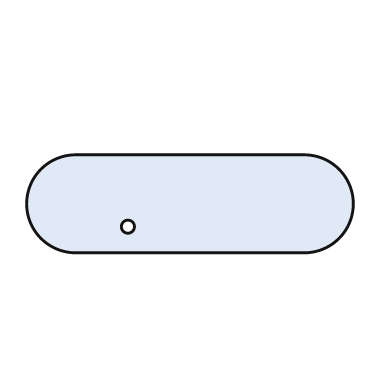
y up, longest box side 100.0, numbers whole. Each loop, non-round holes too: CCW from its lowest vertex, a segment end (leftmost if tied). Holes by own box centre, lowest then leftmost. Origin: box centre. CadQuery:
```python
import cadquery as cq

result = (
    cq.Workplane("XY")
    .moveTo(-35.0, -15.0)
    .lineTo(35.0, -15.0)
    .threePointArc((50.0, 0.0), (35.0, 15.0))
    .lineTo(-35.0, 15.0)
    .threePointArc((-50.0, 0.0), (-35.0, -15.0))
    .close()
    .moveTo(-19.0, -7.0)
    .circle(2.0)
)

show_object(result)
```